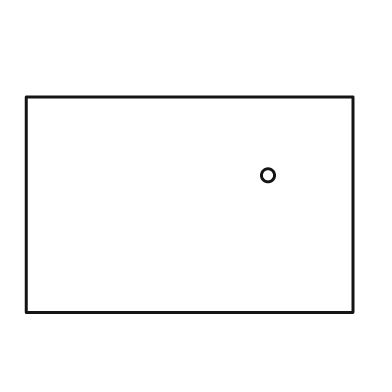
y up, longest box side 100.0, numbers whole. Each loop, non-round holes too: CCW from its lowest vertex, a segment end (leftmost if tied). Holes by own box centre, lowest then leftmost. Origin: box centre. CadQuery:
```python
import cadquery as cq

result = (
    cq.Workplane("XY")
    .moveTo(-50.0, -33.0)
    .lineTo(50.0, -33.0)
    .lineTo(50.0, 33.0)
    .lineTo(-50.0, 33.0)
    .close()
    .moveTo(24.0, 9.0)
    .circle(2.0)
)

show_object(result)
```